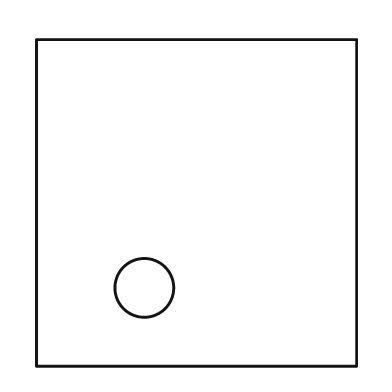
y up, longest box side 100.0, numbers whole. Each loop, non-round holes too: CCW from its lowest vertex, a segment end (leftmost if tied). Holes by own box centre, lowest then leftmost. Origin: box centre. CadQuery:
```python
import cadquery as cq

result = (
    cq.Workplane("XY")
    .moveTo(-49.0, -50.0)
    .lineTo(49.0, -50.0)
    .lineTo(49.0, 50.0)
    .lineTo(-49.0, 50.0)
    .close()
    .moveTo(-16.0, -26.0)
    .circle(9.0)
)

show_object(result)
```